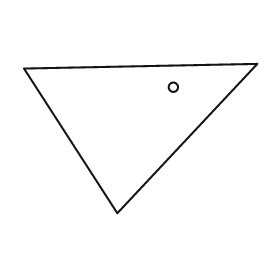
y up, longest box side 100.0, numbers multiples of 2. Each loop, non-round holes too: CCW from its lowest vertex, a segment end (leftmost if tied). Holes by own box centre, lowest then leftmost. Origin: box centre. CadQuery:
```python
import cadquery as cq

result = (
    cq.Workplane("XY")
    .moveTo(-10.0, -32.0)
    .lineTo(50.0, 32.0)
    .lineTo(-50.0, 30.0)
    .close()
    .moveTo(14.0, 22.0)
    .circle(2.0)
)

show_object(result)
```